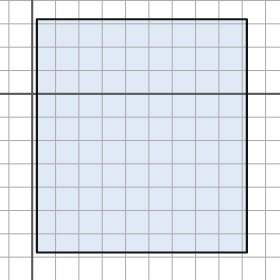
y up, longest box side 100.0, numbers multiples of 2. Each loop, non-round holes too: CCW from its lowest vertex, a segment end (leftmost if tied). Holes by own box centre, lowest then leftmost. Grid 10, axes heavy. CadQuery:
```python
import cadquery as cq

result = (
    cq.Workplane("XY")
    .moveTo(2.0, -68.0)
    .lineTo(92.0, -68.0)
    .lineTo(92.0, 32.0)
    .lineTo(2.0, 32.0)
    .close()
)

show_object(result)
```